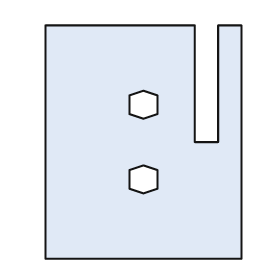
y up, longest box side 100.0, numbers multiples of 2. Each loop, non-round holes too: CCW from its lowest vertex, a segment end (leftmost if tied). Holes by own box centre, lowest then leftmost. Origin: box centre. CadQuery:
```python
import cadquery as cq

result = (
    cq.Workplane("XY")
    .moveTo(-42.0, -50.0)
    .lineTo(42.0, -50.0)
    .lineTo(42.0, 50.0)
    .lineTo(32.0, 50.0)
    .lineTo(32.0, 0.0)
    .lineTo(22.0, 0.0)
    .lineTo(22.0, 50.0)
    .lineTo(-42.0, 50.0)
    .close()
    .moveTo(0.0, -22.0)
    .lineTo(6.0, -20.0)
    .lineTo(6.0, -12.0)
    .lineTo(0.0, -10.0)
    .lineTo(-6.0, -12.0)
    .lineTo(-6.0, -20.0)
    .close()
    .moveTo(0.0, 10.0)
    .lineTo(6.0, 12.0)
    .lineTo(6.0, 20.0)
    .lineTo(0.0, 22.0)
    .lineTo(-6.0, 20.0)
    .lineTo(-6.0, 12.0)
    .close()
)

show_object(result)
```